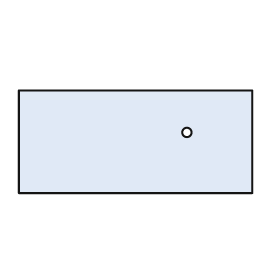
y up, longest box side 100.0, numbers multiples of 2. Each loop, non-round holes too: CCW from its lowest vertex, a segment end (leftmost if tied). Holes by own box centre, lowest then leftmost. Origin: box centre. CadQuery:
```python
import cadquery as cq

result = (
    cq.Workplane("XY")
    .moveTo(-50.0, -22.0)
    .lineTo(50.0, -22.0)
    .lineTo(50.0, 22.0)
    .lineTo(-50.0, 22.0)
    .close()
    .moveTo(22.0, 4.0)
    .circle(2.0)
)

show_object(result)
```